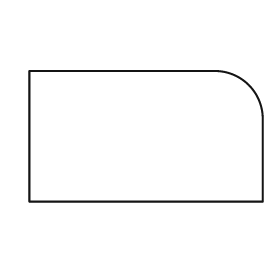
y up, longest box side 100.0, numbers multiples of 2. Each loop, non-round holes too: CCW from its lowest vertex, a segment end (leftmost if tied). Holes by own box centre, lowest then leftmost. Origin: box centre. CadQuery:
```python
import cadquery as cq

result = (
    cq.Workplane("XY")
    .moveTo(-50.0, -28.0)
    .lineTo(50.0, -28.0)
    .lineTo(50.0, 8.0)
    .threePointArc((44.0, 22.0), (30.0, 28.0))
    .lineTo(-50.0, 28.0)
    .close()
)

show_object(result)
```